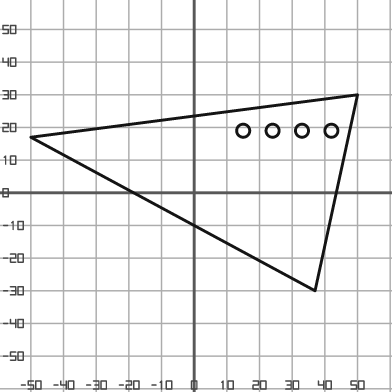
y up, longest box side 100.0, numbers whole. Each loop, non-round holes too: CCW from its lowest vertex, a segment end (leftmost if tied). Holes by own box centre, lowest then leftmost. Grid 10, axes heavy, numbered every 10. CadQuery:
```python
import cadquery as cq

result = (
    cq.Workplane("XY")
    .moveTo(37.0, -30.0)
    .lineTo(50.0, 30.0)
    .lineTo(-50.0, 17.0)
    .close()
    .moveTo(15.0, 19.0)
    .circle(2.0)
    .moveTo(24.0, 19.0)
    .circle(2.0)
    .moveTo(33.0, 19.0)
    .circle(2.0)
    .moveTo(42.0, 19.0)
    .circle(2.0)
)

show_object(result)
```